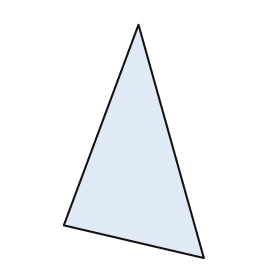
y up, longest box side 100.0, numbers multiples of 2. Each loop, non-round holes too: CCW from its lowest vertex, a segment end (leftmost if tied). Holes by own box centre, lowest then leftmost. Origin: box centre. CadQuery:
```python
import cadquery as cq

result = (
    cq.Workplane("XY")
    .moveTo(30.0, -50.0)
    .lineTo(2.0, 50.0)
    .lineTo(-30.0, -36.0)
    .close()
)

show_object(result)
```